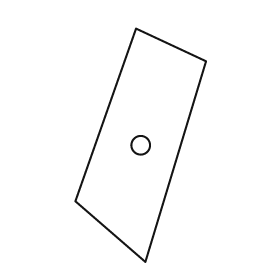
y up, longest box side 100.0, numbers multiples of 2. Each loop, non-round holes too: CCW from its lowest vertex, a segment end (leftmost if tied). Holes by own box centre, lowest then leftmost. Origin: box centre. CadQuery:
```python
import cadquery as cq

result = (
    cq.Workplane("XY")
    .moveTo(2.0, -50.0)
    .lineTo(28.0, 36.0)
    .lineTo(-2.0, 50.0)
    .lineTo(-28.0, -24.0)
    .close()
    .moveTo(0.0, 0.0)
    .circle(4.0)
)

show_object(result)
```